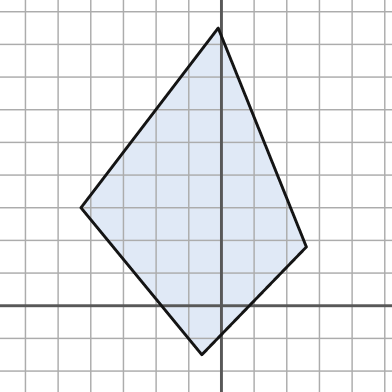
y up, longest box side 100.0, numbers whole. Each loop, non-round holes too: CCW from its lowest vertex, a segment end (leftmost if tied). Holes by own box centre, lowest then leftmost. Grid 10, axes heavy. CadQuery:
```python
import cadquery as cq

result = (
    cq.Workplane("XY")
    .moveTo(-6.0, -15.0)
    .lineTo(26.0, 18.0)
    .lineTo(-1.0, 85.0)
    .lineTo(-43.0, 30.0)
    .close()
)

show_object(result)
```